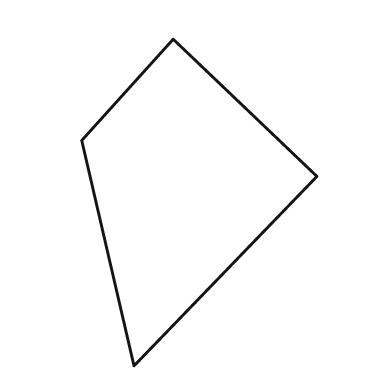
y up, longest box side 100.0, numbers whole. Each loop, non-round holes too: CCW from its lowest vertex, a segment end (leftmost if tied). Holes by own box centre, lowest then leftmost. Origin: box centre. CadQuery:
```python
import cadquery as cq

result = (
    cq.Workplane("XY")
    .moveTo(-20.0, -50.0)
    .lineTo(36.0, 8.0)
    .lineTo(-8.0, 50.0)
    .lineTo(-36.0, 19.0)
    .close()
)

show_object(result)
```